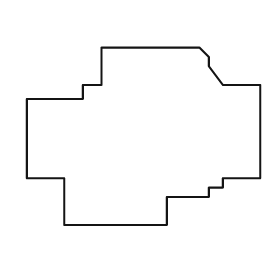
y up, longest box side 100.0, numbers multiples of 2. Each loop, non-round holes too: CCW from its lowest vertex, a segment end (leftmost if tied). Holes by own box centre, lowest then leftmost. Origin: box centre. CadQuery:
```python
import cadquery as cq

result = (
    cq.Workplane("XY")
    .moveTo(-34.0, -38.0)
    .lineTo(10.0, -38.0)
    .lineTo(10.0, -26.0)
    .lineTo(28.0, -26.0)
    .lineTo(28.0, -22.0)
    .lineTo(34.0, -22.0)
    .lineTo(34.0, -18.0)
    .lineTo(50.0, -18.0)
    .lineTo(50.0, 22.0)
    .lineTo(34.0, 22.0)
    .lineTo(28.0, 30.0)
    .lineTo(28.0, 34.0)
    .lineTo(24.0, 38.0)
    .lineTo(-18.0, 38.0)
    .lineTo(-18.0, 22.0)
    .lineTo(-26.0, 22.0)
    .lineTo(-26.0, 16.0)
    .lineTo(-50.0, 16.0)
    .lineTo(-50.0, -18.0)
    .lineTo(-34.0, -18.0)
    .close()
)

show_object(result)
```